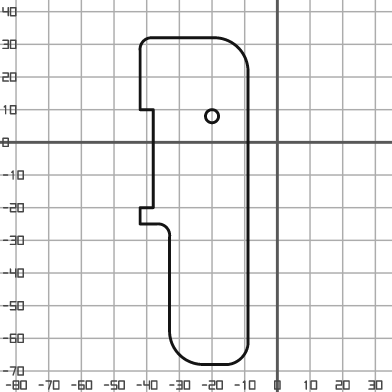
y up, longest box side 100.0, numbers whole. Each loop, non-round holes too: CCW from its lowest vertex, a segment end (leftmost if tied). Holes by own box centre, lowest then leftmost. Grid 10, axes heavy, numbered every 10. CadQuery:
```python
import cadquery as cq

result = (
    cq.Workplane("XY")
    .moveTo(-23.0, -68.0)
    .lineTo(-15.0, -68.0)
    .threePointArc((-11.0, -66.0), (-9.0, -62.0))
    .lineTo(-9.0, 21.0)
    .threePointArc((-12.0, 29.0), (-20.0, 32.0))
    .lineTo(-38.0, 32.0)
    .threePointArc((-41.0, 31.0), (-42.0, 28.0))
    .lineTo(-42.0, 10.0)
    .lineTo(-38.0, 10.0)
    .lineTo(-38.0, -20.0)
    .lineTo(-42.0, -20.0)
    .lineTo(-42.0, -25.0)
    .lineTo(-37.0, -25.0)
    .threePointArc((-34.0, -26.0), (-33.0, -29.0))
    .lineTo(-33.0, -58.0)
    .threePointArc((-30.0, -65.0), (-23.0, -68.0))
    .close()
    .moveTo(-20.0, 8.0)
    .circle(2.0)
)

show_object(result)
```